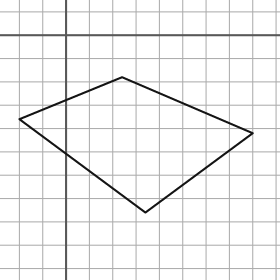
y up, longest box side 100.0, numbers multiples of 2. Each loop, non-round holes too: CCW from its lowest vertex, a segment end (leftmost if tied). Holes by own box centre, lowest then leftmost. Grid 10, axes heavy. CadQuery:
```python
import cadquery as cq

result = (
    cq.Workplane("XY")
    .moveTo(34.0, -76.0)
    .lineTo(80.0, -42.0)
    .lineTo(24.0, -18.0)
    .lineTo(-20.0, -36.0)
    .close()
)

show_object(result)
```